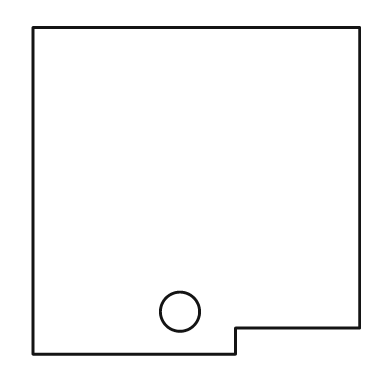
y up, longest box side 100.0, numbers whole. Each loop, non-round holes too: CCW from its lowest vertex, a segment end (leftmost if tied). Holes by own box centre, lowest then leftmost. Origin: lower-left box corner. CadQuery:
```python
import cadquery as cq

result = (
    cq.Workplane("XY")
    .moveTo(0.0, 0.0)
    .lineTo(62.0, 0.0)
    .lineTo(62.0, 8.0)
    .lineTo(100.0, 8.0)
    .lineTo(100.0, 100.0)
    .lineTo(0.0, 100.0)
    .close()
    .moveTo(45.0, 13.0)
    .circle(6.0)
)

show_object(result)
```